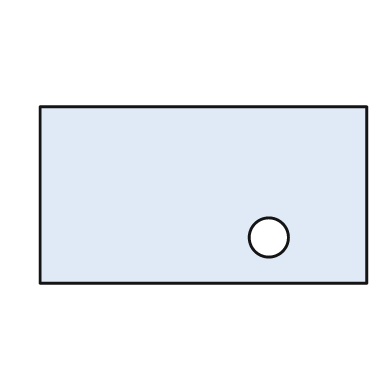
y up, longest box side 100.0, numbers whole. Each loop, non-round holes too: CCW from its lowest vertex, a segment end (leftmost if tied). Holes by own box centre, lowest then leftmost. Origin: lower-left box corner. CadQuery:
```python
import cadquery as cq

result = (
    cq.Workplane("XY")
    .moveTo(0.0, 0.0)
    .lineTo(100.0, 0.0)
    .lineTo(100.0, 54.0)
    .lineTo(0.0, 54.0)
    .close()
    .moveTo(70.0, 14.0)
    .circle(6.0)
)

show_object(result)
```